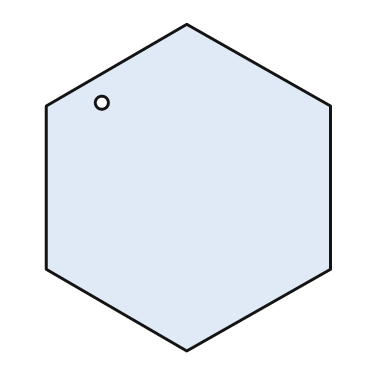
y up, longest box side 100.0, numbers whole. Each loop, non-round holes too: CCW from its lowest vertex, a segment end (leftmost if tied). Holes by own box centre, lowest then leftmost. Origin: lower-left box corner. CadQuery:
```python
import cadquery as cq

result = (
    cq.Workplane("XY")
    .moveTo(43.0, 0.0)
    .lineTo(87.0, 25.0)
    .lineTo(87.0, 75.0)
    .lineTo(43.0, 100.0)
    .lineTo(0.0, 75.0)
    .lineTo(0.0, 25.0)
    .close()
    .moveTo(17.0, 76.0)
    .circle(2.0)
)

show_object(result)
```